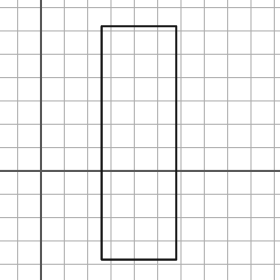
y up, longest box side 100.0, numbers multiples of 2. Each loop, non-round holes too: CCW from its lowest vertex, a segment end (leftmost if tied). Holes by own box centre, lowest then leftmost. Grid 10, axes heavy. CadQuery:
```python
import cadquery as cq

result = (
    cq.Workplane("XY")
    .moveTo(26.0, -38.0)
    .lineTo(58.0, -38.0)
    .lineTo(58.0, 62.0)
    .lineTo(26.0, 62.0)
    .close()
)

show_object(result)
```